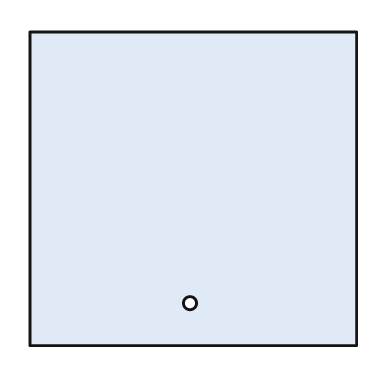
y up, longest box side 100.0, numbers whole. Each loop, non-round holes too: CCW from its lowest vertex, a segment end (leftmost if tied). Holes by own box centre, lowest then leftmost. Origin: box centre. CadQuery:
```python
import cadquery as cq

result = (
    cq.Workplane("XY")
    .moveTo(-50.0, -48.0)
    .lineTo(50.0, -48.0)
    .lineTo(50.0, 48.0)
    .lineTo(-50.0, 48.0)
    .close()
    .moveTo(-1.0, -35.0)
    .circle(2.0)
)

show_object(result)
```